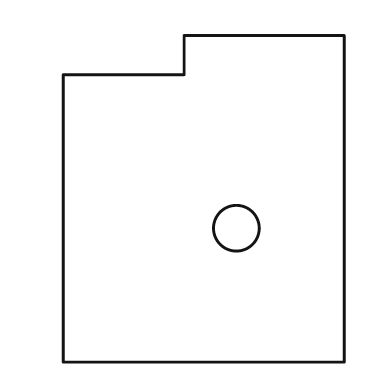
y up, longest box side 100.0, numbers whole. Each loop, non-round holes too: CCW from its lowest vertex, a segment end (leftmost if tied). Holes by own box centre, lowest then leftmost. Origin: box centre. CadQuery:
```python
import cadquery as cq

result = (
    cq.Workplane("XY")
    .moveTo(-43.0, -50.0)
    .lineTo(43.0, -50.0)
    .lineTo(43.0, 50.0)
    .lineTo(-6.0, 50.0)
    .lineTo(-6.0, 38.0)
    .lineTo(-43.0, 38.0)
    .close()
    .moveTo(10.0, -9.0)
    .circle(7.0)
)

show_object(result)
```